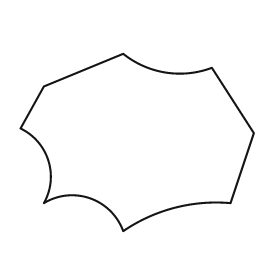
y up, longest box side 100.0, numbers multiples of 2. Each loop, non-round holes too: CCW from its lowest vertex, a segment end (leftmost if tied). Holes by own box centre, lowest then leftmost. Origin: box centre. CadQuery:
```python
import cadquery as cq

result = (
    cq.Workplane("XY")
    .moveTo(-6.0, -38.0)
    .threePointArc((16.0, -28.0), (40.0, -26.0))
    .lineTo(50.0, 4.0)
    .lineTo(32.0, 32.0)
    .threePointArc((12.0, 30.0), (-6.0, 38.0))
    .lineTo(-40.0, 24.0)
    .lineTo(-50.0, 6.0)
    .threePointArc((-38.0, -8.0), (-40.0, -26.0))
    .threePointArc((-20.0, -24.0), (-6.0, -38.0))
    .close()
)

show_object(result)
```